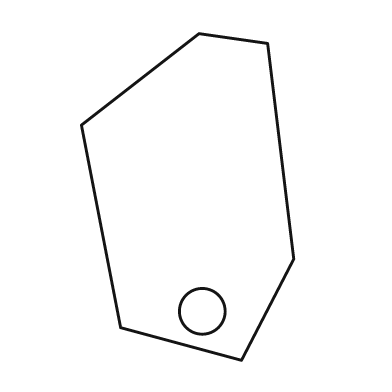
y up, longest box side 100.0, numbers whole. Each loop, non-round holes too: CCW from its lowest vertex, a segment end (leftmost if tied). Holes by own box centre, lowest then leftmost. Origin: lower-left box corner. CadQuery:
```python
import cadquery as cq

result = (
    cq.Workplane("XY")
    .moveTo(49.0, 0.0)
    .lineTo(65.0, 31.0)
    .lineTo(57.0, 97.0)
    .lineTo(36.0, 100.0)
    .lineTo(0.0, 72.0)
    .lineTo(12.0, 10.0)
    .close()
    .moveTo(37.0, 15.0)
    .circle(7.0)
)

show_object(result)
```